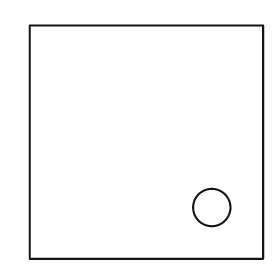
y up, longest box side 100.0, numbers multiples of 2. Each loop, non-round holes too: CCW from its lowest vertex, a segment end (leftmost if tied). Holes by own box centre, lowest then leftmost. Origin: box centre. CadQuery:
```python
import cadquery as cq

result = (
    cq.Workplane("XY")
    .moveTo(-50.0, -50.0)
    .lineTo(50.0, -50.0)
    .lineTo(50.0, 50.0)
    .lineTo(-50.0, 50.0)
    .close()
    .moveTo(28.0, -28.0)
    .circle(8.0)
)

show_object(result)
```